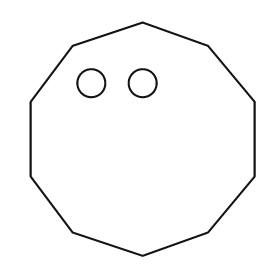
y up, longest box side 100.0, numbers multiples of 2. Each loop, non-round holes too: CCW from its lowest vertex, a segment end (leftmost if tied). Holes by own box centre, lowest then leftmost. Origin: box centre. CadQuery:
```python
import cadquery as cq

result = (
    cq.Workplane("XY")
    .moveTo(0.0, -50.0)
    .lineTo(28.0, -40.0)
    .lineTo(48.0, -16.0)
    .lineTo(48.0, 16.0)
    .lineTo(28.0, 40.0)
    .lineTo(0.0, 50.0)
    .lineTo(-30.0, 40.0)
    .lineTo(-48.0, 16.0)
    .lineTo(-48.0, -16.0)
    .lineTo(-30.0, -40.0)
    .close()
    .moveTo(-22.0, 24.0)
    .circle(6.0)
    .moveTo(0.0, 24.0)
    .circle(6.0)
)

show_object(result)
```